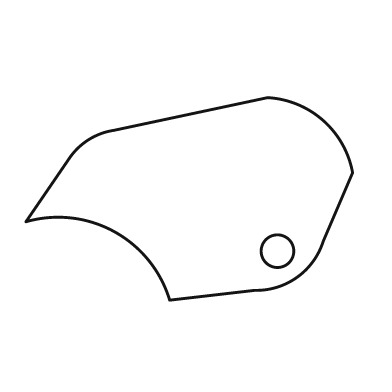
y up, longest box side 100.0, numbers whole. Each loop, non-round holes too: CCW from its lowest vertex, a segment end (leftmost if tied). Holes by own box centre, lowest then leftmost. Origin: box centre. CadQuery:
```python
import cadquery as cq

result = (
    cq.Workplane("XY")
    .moveTo(-6.0, -31.0)
    .lineTo(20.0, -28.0)
    .threePointArc((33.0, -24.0), (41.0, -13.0))
    .lineTo(50.0, 8.0)
    .threePointArc((41.0, 24.0), (24.0, 31.0))
    .lineTo(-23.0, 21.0)
    .threePointArc((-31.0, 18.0), (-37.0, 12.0))
    .lineTo(-50.0, -7.0)
    .threePointArc((-23.0, -10.0), (-6.0, -31.0))
    .close()
    .moveTo(27.0, -16.0)
    .circle(5.0)
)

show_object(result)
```